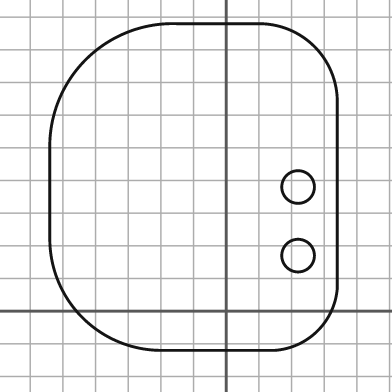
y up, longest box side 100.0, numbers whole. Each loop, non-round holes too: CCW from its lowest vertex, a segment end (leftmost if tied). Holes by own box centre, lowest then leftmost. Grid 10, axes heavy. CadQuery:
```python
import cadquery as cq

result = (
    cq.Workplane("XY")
    .moveTo(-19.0, -12.0)
    .lineTo(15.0, -12.0)
    .threePointArc((28.0, -6.0), (34.0, 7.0))
    .lineTo(34.0, 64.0)
    .threePointArc((27.0, 81.0), (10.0, 88.0))
    .lineTo(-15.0, 88.0)
    .threePointArc((-43.0, 77.0), (-54.0, 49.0))
    .lineTo(-54.0, 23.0)
    .threePointArc((-44.0, -2.0), (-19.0, -12.0))
    .close()
    .moveTo(22.0, 17.0)
    .circle(5.0)
    .moveTo(22.0, 38.0)
    .circle(5.0)
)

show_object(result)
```